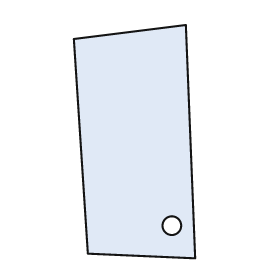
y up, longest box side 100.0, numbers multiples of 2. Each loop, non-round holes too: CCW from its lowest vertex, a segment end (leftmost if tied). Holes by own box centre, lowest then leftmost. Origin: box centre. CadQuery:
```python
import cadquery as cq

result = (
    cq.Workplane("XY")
    .moveTo(26.0, -50.0)
    .lineTo(22.0, 50.0)
    .lineTo(-26.0, 44.0)
    .lineTo(-20.0, -48.0)
    .close()
    .moveTo(16.0, -36.0)
    .circle(4.0)
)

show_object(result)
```